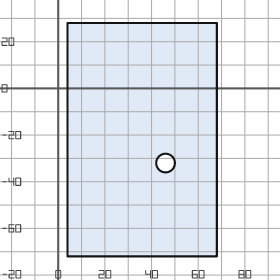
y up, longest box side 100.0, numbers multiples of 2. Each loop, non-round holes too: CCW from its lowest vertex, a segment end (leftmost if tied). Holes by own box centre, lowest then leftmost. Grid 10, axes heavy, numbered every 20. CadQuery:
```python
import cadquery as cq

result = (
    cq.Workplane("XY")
    .moveTo(4.0, -72.0)
    .lineTo(68.0, -72.0)
    .lineTo(68.0, 28.0)
    .lineTo(4.0, 28.0)
    .close()
    .moveTo(46.0, -32.0)
    .circle(4.0)
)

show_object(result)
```